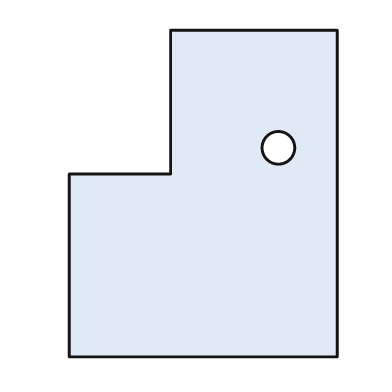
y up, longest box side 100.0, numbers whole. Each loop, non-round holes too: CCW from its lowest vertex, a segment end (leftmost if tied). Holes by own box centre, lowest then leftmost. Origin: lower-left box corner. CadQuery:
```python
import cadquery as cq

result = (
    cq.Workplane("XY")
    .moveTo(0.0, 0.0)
    .lineTo(82.0, 0.0)
    .lineTo(82.0, 100.0)
    .lineTo(31.0, 100.0)
    .lineTo(31.0, 56.0)
    .lineTo(0.0, 56.0)
    .close()
    .moveTo(64.0, 64.0)
    .circle(5.0)
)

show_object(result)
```